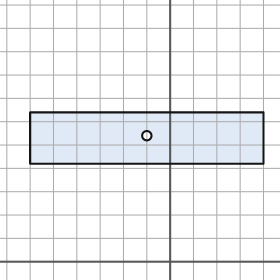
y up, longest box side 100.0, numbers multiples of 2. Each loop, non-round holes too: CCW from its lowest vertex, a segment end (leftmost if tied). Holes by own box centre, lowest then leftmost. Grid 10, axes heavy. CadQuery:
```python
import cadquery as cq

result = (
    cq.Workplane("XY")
    .moveTo(-60.0, 42.0)
    .lineTo(40.0, 42.0)
    .lineTo(40.0, 64.0)
    .lineTo(-60.0, 64.0)
    .close()
    .moveTo(-10.0, 54.0)
    .circle(2.0)
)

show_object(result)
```